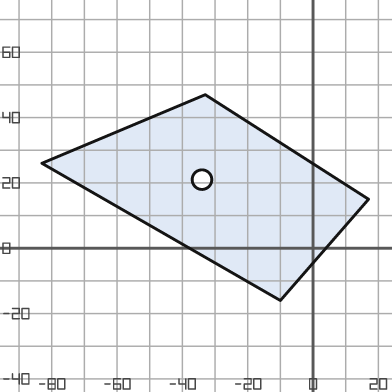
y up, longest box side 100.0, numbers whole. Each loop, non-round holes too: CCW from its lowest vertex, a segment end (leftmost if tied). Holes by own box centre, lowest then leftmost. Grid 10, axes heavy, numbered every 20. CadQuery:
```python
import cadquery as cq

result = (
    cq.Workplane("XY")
    .moveTo(-10.0, -16.0)
    .lineTo(17.0, 15.0)
    .lineTo(-33.0, 47.0)
    .lineTo(-83.0, 26.0)
    .close()
    .moveTo(-34.0, 21.0)
    .circle(3.0)
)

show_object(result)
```